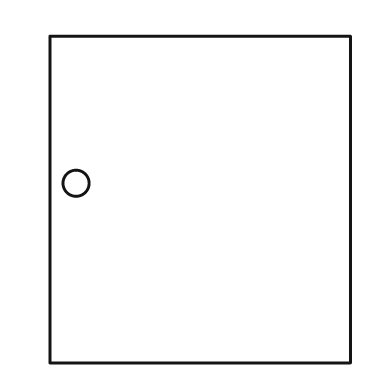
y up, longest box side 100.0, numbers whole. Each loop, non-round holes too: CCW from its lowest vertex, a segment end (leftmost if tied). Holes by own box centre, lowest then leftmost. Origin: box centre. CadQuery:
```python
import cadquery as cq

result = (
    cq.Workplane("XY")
    .moveTo(-46.0, -50.0)
    .lineTo(46.0, -50.0)
    .lineTo(46.0, 50.0)
    .lineTo(-46.0, 50.0)
    .close()
    .moveTo(-38.0, 5.0)
    .circle(4.0)
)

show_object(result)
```